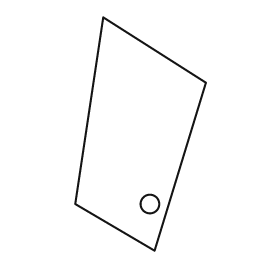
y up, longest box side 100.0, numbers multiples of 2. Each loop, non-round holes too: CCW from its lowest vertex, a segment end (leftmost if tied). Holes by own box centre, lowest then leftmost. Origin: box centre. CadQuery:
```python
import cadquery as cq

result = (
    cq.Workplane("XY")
    .moveTo(6.0, -50.0)
    .lineTo(28.0, 22.0)
    .lineTo(-16.0, 50.0)
    .lineTo(-28.0, -30.0)
    .close()
    .moveTo(4.0, -30.0)
    .circle(4.0)
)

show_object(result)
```